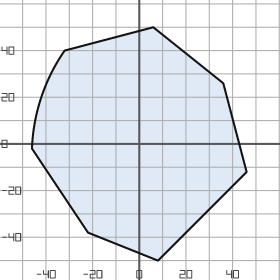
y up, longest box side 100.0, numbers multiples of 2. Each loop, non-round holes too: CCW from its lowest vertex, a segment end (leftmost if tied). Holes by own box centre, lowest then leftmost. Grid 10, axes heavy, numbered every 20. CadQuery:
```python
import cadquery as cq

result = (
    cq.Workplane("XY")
    .moveTo(8.0, -50.0)
    .lineTo(46.0, -12.0)
    .lineTo(36.0, 26.0)
    .lineTo(6.0, 50.0)
    .lineTo(-32.0, 40.0)
    .threePointArc((-42.0, 20.0), (-46.0, -2.0))
    .lineTo(-22.0, -38.0)
    .close()
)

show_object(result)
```